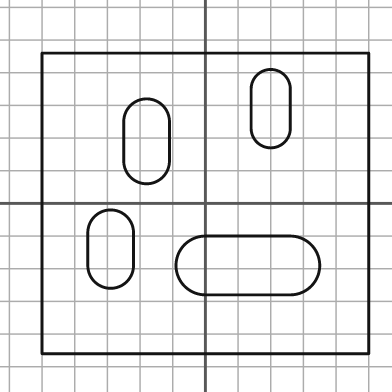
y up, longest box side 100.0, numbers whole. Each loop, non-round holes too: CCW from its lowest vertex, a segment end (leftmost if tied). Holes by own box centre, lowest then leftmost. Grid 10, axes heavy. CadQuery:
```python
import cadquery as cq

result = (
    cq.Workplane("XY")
    .moveTo(-50.0, -46.0)
    .lineTo(50.0, -46.0)
    .lineTo(50.0, 46.0)
    .lineTo(-50.0, 46.0)
    .close()
    .moveTo(0.0, -28.0)
    .lineTo(26.0, -28.0)
    .threePointArc((35.0, -19.0), (26.0, -10.0))
    .lineTo(0.0, -10.0)
    .threePointArc((-9.0, -19.0), (0.0, -28.0))
    .close()
    .moveTo(-36.0, -19.0)
    .threePointArc((-29.0, -26.0), (-22.0, -19.0))
    .lineTo(-22.0, -9.0)
    .threePointArc((-29.0, -2.0), (-36.0, -9.0))
    .close()
    .moveTo(-25.0, 13.0)
    .threePointArc((-18.0, 6.0), (-11.0, 13.0))
    .lineTo(-11.0, 25.0)
    .threePointArc((-18.0, 32.0), (-25.0, 25.0))
    .close()
    .moveTo(14.0, 23.0)
    .threePointArc((20.0, 17.0), (26.0, 23.0))
    .lineTo(26.0, 35.0)
    .threePointArc((20.0, 41.0), (14.0, 35.0))
    .close()
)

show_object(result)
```